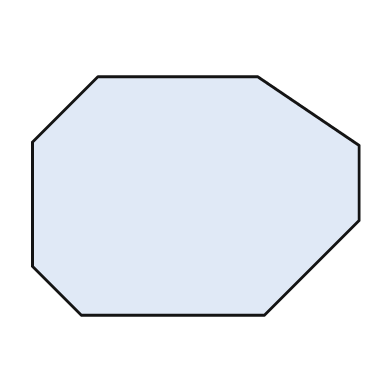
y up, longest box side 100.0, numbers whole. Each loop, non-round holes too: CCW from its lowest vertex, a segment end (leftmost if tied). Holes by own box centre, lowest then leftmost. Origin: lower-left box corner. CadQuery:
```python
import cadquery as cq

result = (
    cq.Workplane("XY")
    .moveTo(15.0, 0.0)
    .lineTo(71.0, 0.0)
    .lineTo(100.0, 29.0)
    .lineTo(100.0, 52.0)
    .lineTo(69.0, 73.0)
    .lineTo(20.0, 73.0)
    .lineTo(0.0, 53.0)
    .lineTo(0.0, 15.0)
    .close()
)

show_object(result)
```